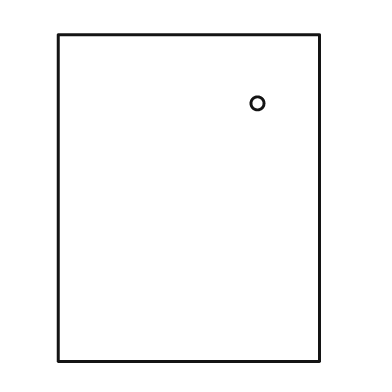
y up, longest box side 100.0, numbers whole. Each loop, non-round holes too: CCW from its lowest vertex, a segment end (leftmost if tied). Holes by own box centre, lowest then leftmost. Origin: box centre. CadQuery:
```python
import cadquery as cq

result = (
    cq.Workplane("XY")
    .moveTo(-40.0, -50.0)
    .lineTo(40.0, -50.0)
    .lineTo(40.0, 50.0)
    .lineTo(-40.0, 50.0)
    .close()
    .moveTo(21.0, 29.0)
    .circle(2.0)
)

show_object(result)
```